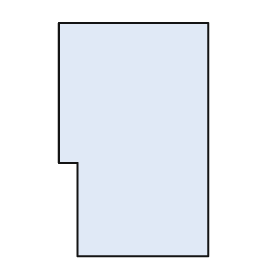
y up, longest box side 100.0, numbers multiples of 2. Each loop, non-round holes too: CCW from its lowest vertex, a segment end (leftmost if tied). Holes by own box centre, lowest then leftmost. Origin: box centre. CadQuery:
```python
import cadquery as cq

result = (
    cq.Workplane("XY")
    .moveTo(-24.0, -50.0)
    .lineTo(32.0, -50.0)
    .lineTo(32.0, 50.0)
    .lineTo(-32.0, 50.0)
    .lineTo(-32.0, -10.0)
    .lineTo(-24.0, -10.0)
    .close()
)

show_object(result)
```